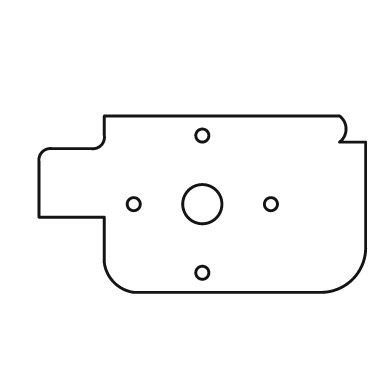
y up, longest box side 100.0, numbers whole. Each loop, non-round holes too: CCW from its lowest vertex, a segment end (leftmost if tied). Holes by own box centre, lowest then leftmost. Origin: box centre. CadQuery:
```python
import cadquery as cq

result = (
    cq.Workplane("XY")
    .moveTo(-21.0, -27.0)
    .lineTo(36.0, -27.0)
    .threePointArc((46.0, -23.0), (50.0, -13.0))
    .lineTo(50.0, 19.0)
    .lineTo(42.0, 19.0)
    .threePointArc((44.0, 23.0), (42.0, 27.0))
    .lineTo(-30.0, 27.0)
    .lineTo(-30.0, 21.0)
    .threePointArc((-31.0, 18.0), (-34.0, 17.0))
    .lineTo(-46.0, 17.0)
    .threePointArc((-49.0, 16.0), (-50.0, 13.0))
    .lineTo(-50.0, -4.0)
    .lineTo(-30.0, -4.0)
    .lineTo(-30.0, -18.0)
    .threePointArc((-27.0, -24.0), (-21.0, -27.0))
    .close()
    .moveTo(0.0, -21.0)
    .circle(2.0)
    .moveTo(-21.0, 0.0)
    .circle(2.0)
    .moveTo(0.0, 0.0)
    .circle(6.0)
    .moveTo(21.0, 0.0)
    .circle(2.0)
    .moveTo(0.0, 21.0)
    .circle(2.0)
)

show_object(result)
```